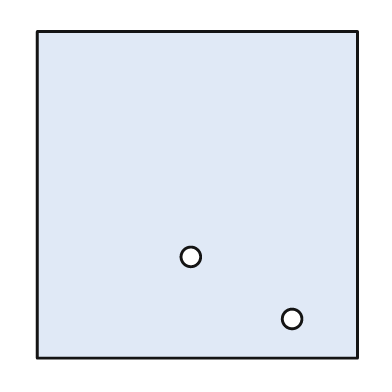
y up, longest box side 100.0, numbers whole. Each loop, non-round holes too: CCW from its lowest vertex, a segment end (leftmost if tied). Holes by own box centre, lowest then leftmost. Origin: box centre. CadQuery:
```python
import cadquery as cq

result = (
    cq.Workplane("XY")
    .moveTo(-49.0, -50.0)
    .lineTo(49.0, -50.0)
    .lineTo(49.0, 50.0)
    .lineTo(-49.0, 50.0)
    .close()
    .moveTo(29.0, -38.0)
    .circle(3.0)
    .moveTo(-2.0, -19.0)
    .circle(3.0)
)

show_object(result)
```